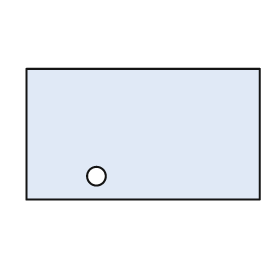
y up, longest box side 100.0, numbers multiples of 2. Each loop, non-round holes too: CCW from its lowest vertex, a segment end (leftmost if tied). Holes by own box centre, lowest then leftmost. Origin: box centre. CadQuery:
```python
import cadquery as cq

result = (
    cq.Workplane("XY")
    .moveTo(-50.0, -28.0)
    .lineTo(50.0, -28.0)
    .lineTo(50.0, 28.0)
    .lineTo(-50.0, 28.0)
    .close()
    .moveTo(-20.0, -18.0)
    .circle(4.0)
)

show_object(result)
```